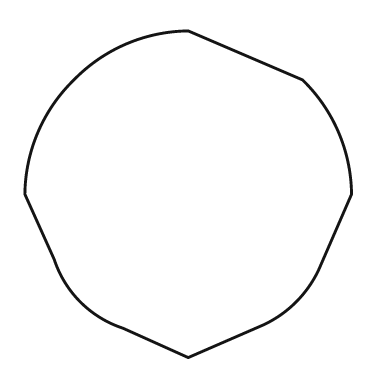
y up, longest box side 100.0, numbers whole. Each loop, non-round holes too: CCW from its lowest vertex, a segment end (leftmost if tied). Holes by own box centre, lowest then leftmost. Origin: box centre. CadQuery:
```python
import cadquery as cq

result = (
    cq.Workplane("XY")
    .moveTo(0.0, -50.0)
    .lineTo(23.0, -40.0)
    .threePointArc((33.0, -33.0), (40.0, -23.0))
    .lineTo(50.0, 0.0)
    .threePointArc((46.0, 19.0), (35.0, 35.0))
    .lineTo(0.0, 50.0)
    .threePointArc((-19.0, 46.0), (-35.0, 35.0))
    .threePointArc((-46.0, 19.0), (-50.0, 0.0))
    .lineTo(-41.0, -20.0)
    .threePointArc((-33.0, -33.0), (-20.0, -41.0))
    .close()
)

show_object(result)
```